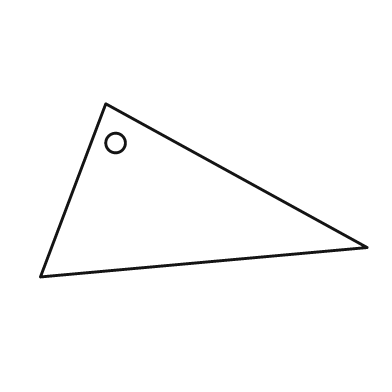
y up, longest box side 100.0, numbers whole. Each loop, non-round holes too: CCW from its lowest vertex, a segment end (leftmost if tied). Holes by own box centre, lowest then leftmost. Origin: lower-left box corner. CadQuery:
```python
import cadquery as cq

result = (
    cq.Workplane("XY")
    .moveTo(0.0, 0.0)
    .lineTo(100.0, 9.0)
    .lineTo(20.0, 53.0)
    .close()
    .moveTo(23.0, 41.0)
    .circle(3.0)
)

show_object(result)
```